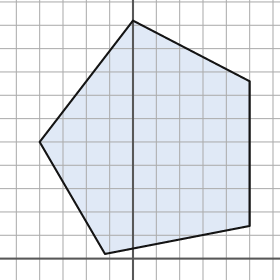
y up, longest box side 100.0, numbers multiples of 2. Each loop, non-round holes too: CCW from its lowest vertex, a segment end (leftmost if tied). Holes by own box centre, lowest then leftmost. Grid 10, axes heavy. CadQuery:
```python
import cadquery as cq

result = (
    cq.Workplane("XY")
    .moveTo(-12.0, 2.0)
    .lineTo(50.0, 14.0)
    .lineTo(50.0, 76.0)
    .lineTo(0.0, 102.0)
    .lineTo(-40.0, 50.0)
    .close()
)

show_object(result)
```